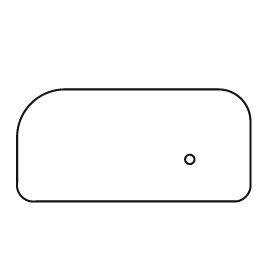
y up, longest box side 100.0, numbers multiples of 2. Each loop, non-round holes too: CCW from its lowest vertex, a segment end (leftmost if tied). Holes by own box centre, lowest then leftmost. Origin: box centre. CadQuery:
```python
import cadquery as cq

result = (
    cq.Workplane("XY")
    .moveTo(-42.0, -24.0)
    .lineTo(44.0, -24.0)
    .threePointArc((48.0, -22.0), (50.0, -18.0))
    .lineTo(50.0, 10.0)
    .threePointArc((46.0, 20.0), (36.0, 24.0))
    .lineTo(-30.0, 24.0)
    .threePointArc((-44.0, 18.0), (-50.0, 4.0))
    .lineTo(-50.0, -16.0)
    .threePointArc((-48.0, -22.0), (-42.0, -24.0))
    .close()
    .moveTo(24.0, -6.0)
    .circle(2.0)
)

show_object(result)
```